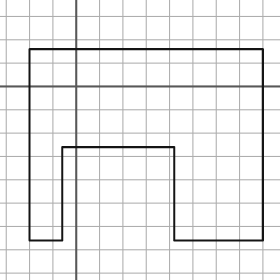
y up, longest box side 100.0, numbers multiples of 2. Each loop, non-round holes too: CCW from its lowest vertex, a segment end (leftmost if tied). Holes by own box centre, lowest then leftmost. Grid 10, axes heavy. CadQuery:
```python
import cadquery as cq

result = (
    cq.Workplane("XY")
    .moveTo(-20.0, -66.0)
    .lineTo(-6.0, -66.0)
    .lineTo(-6.0, -26.0)
    .lineTo(42.0, -26.0)
    .lineTo(42.0, -66.0)
    .lineTo(80.0, -66.0)
    .lineTo(80.0, 16.0)
    .lineTo(-20.0, 16.0)
    .close()
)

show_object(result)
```